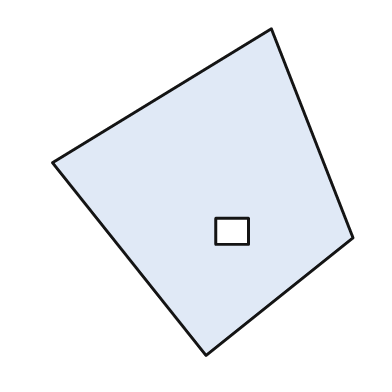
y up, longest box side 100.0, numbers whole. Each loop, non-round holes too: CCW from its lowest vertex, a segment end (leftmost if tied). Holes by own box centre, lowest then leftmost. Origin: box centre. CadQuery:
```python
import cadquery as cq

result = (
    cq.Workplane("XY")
    .moveTo(1.0, -50.0)
    .lineTo(46.0, -14.0)
    .lineTo(21.0, 50.0)
    .lineTo(-46.0, 9.0)
    .close()
    .moveTo(4.0, -16.0)
    .lineTo(14.0, -16.0)
    .lineTo(14.0, -8.0)
    .lineTo(4.0, -8.0)
    .close()
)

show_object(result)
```